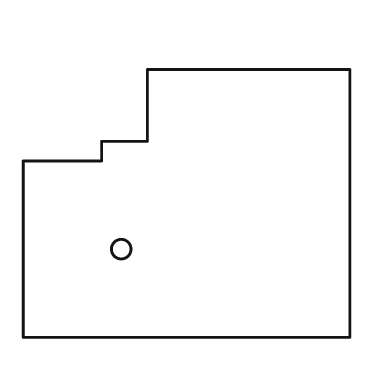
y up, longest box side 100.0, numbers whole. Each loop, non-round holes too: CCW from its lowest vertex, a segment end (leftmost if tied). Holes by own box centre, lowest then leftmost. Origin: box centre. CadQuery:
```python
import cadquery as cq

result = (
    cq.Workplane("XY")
    .moveTo(-50.0, -41.0)
    .lineTo(50.0, -41.0)
    .lineTo(50.0, 41.0)
    .lineTo(-12.0, 41.0)
    .lineTo(-12.0, 19.0)
    .lineTo(-26.0, 19.0)
    .lineTo(-26.0, 13.0)
    .lineTo(-50.0, 13.0)
    .close()
    .moveTo(-20.0, -14.0)
    .circle(3.0)
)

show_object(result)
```